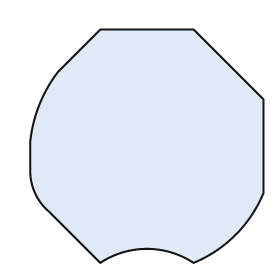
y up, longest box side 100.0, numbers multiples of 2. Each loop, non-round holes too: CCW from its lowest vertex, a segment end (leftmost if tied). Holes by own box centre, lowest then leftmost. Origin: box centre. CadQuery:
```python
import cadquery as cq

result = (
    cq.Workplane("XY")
    .moveTo(-20.0, -50.0)
    .threePointArc((0.0, -44.0), (20.0, -50.0))
    .threePointArc((38.0, -38.0), (50.0, -20.0))
    .lineTo(50.0, 20.0)
    .lineTo(20.0, 50.0)
    .lineTo(-20.0, 50.0)
    .lineTo(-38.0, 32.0)
    .threePointArc((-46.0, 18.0), (-50.0, 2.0))
    .lineTo(-50.0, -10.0)
    .threePointArc((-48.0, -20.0), (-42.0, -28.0))
    .close()
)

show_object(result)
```